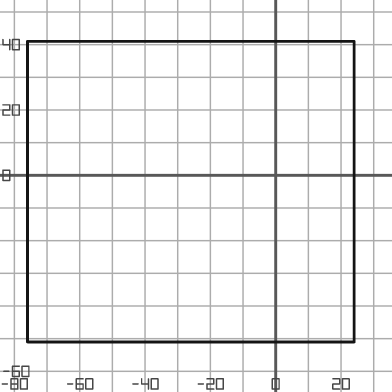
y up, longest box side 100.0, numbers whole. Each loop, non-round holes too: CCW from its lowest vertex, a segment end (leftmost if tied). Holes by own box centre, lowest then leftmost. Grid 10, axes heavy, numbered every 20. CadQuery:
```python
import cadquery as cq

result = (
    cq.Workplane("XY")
    .moveTo(-76.0, -51.0)
    .lineTo(24.0, -51.0)
    .lineTo(24.0, 41.0)
    .lineTo(-76.0, 41.0)
    .close()
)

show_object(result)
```